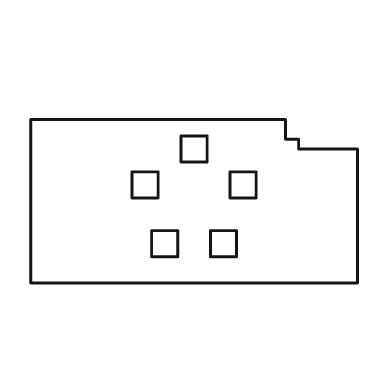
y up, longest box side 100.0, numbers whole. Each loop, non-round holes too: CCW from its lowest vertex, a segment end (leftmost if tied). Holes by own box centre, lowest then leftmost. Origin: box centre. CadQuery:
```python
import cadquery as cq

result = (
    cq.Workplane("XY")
    .moveTo(-50.0, -25.0)
    .lineTo(50.0, -25.0)
    .lineTo(50.0, 16.0)
    .lineTo(32.0, 16.0)
    .lineTo(32.0, 19.0)
    .lineTo(28.0, 19.0)
    .lineTo(28.0, 25.0)
    .lineTo(-50.0, 25.0)
    .close()
    .moveTo(-13.0, -17.0)
    .lineTo(-5.0, -17.0)
    .lineTo(-5.0, -9.0)
    .lineTo(-13.0, -9.0)
    .close()
    .moveTo(5.0, -17.0)
    .lineTo(13.0, -17.0)
    .lineTo(13.0, -9.0)
    .lineTo(5.0, -9.0)
    .close()
    .moveTo(-19.0, 1.0)
    .lineTo(-11.0, 1.0)
    .lineTo(-11.0, 9.0)
    .lineTo(-19.0, 9.0)
    .close()
    .moveTo(11.0, 1.0)
    .lineTo(19.0, 1.0)
    .lineTo(19.0, 9.0)
    .lineTo(11.0, 9.0)
    .close()
    .moveTo(-4.0, 12.0)
    .lineTo(4.0, 12.0)
    .lineTo(4.0, 20.0)
    .lineTo(-4.0, 20.0)
    .close()
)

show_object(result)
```